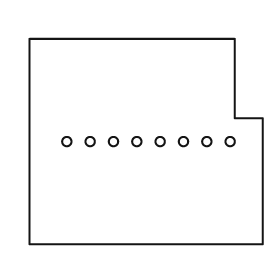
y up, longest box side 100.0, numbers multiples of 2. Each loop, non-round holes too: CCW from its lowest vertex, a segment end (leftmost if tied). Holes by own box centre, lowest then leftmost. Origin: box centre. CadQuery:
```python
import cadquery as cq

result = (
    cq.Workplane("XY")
    .moveTo(-50.0, -44.0)
    .lineTo(50.0, -44.0)
    .lineTo(50.0, 10.0)
    .lineTo(38.0, 10.0)
    .lineTo(38.0, 44.0)
    .lineTo(-50.0, 44.0)
    .close()
    .moveTo(-34.0, 0.0)
    .circle(2.0)
    .moveTo(-24.0, 0.0)
    .circle(2.0)
    .moveTo(-14.0, 0.0)
    .circle(2.0)
    .moveTo(-4.0, 0.0)
    .circle(2.0)
    .moveTo(6.0, 0.0)
    .circle(2.0)
    .moveTo(16.0, 0.0)
    .circle(2.0)
    .moveTo(26.0, 0.0)
    .circle(2.0)
    .moveTo(36.0, 0.0)
    .circle(2.0)
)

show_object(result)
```